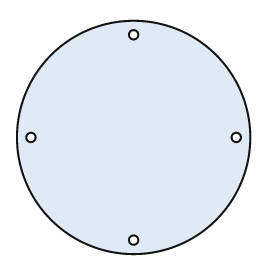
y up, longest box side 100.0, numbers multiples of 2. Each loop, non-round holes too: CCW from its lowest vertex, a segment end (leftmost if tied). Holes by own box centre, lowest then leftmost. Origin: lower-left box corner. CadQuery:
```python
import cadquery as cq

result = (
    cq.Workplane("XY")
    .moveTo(50.0, 50.0)
    .circle(50.0)
    .moveTo(50.0, 6.0)
    .circle(2.0)
    .moveTo(6.0, 50.0)
    .circle(2.0)
    .moveTo(94.0, 50.0)
    .circle(2.0)
    .moveTo(50.0, 94.0)
    .circle(2.0)
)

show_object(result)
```